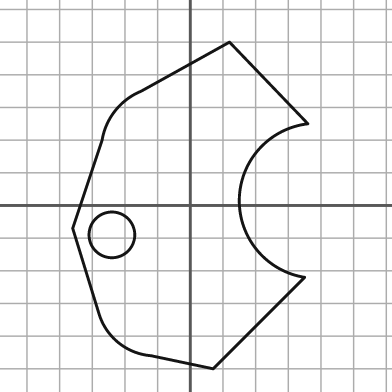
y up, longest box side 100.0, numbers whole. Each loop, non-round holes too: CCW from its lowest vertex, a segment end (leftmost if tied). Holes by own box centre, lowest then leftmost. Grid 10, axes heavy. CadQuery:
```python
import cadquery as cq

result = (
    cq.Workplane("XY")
    .moveTo(7.0, -50.0)
    .lineTo(35.0, -22.0)
    .threePointArc((15.0, 2.0), (36.0, 25.0))
    .lineTo(12.0, 50.0)
    .lineTo(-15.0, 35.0)
    .threePointArc((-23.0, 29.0), (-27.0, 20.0))
    .lineTo(-36.0, -7.0)
    .lineTo(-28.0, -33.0)
    .threePointArc((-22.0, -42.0), (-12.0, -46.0))
    .close()
    .moveTo(-24.0, -9.0)
    .circle(7.0)
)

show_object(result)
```